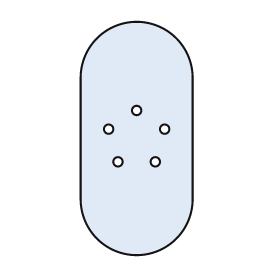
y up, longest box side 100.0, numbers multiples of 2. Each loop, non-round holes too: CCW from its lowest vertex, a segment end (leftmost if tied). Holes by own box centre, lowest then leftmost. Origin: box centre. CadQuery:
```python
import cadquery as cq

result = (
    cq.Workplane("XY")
    .moveTo(-24.0, -26.0)
    .threePointArc((0.0, -50.0), (24.0, -26.0))
    .lineTo(24.0, 26.0)
    .threePointArc((0.0, 50.0), (-24.0, 26.0))
    .close()
    .moveTo(-8.0, -10.0)
    .circle(2.0)
    .moveTo(8.0, -10.0)
    .circle(2.0)
    .moveTo(-12.0, 4.0)
    .circle(2.0)
    .moveTo(12.0, 4.0)
    .circle(2.0)
    .moveTo(0.0, 12.0)
    .circle(2.0)
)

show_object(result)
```